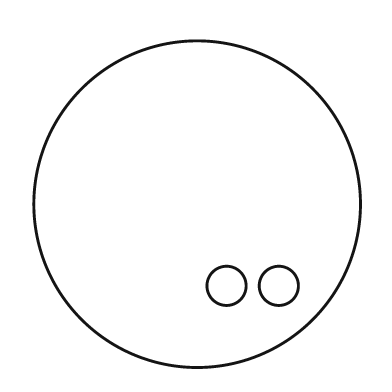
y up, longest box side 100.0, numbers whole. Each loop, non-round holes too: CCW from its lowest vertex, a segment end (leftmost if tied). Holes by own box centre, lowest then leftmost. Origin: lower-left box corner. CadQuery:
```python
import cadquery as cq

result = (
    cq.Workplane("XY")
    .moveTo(50.0, 50.0)
    .circle(50.0)
    .moveTo(59.0, 25.0)
    .circle(6.0)
    .moveTo(75.0, 25.0)
    .circle(6.0)
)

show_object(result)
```